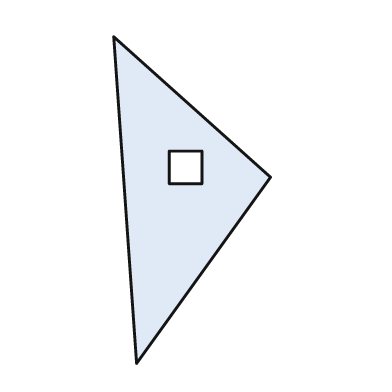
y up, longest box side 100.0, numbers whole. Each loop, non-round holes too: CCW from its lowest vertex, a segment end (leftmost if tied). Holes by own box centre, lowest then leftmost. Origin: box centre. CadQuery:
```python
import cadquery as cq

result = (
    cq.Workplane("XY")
    .moveTo(-17.0, -50.0)
    .lineTo(24.0, 7.0)
    .lineTo(-24.0, 50.0)
    .close()
    .moveTo(-7.0, 5.0)
    .lineTo(3.0, 5.0)
    .lineTo(3.0, 15.0)
    .lineTo(-7.0, 15.0)
    .close()
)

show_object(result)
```